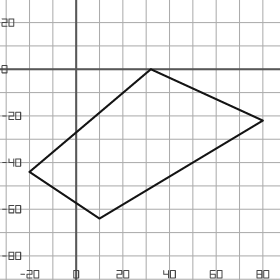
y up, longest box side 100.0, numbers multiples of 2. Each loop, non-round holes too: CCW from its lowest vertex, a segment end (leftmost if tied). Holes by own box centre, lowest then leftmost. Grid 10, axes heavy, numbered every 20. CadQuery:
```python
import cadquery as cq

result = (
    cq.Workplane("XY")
    .moveTo(10.0, -64.0)
    .lineTo(80.0, -22.0)
    .lineTo(32.0, 0.0)
    .lineTo(-20.0, -44.0)
    .close()
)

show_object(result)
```